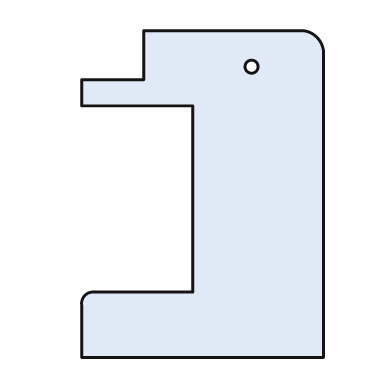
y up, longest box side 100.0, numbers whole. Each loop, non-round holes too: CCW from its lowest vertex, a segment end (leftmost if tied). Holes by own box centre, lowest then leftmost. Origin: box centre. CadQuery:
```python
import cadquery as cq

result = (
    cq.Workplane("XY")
    .moveTo(-37.0, -50.0)
    .lineTo(37.0, -50.0)
    .lineTo(37.0, 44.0)
    .threePointArc((35.0, 48.0), (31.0, 50.0))
    .lineTo(-18.0, 50.0)
    .lineTo(-18.0, 35.0)
    .lineTo(-37.0, 35.0)
    .lineTo(-37.0, 27.0)
    .lineTo(-3.0, 27.0)
    .lineTo(-3.0, -30.0)
    .lineTo(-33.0, -30.0)
    .threePointArc((-36.0, -31.0), (-37.0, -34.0))
    .close()
    .moveTo(15.0, 39.0)
    .circle(2.0)
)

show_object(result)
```